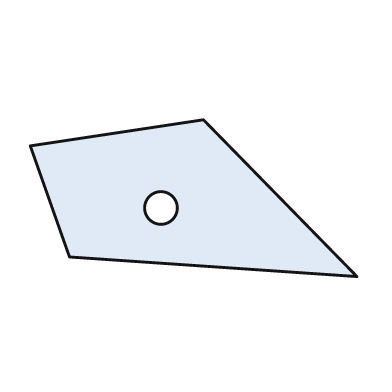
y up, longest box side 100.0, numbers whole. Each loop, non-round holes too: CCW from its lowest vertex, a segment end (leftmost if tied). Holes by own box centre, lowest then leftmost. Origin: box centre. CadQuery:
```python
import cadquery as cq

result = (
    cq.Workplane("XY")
    .moveTo(50.0, -24.0)
    .lineTo(3.0, 24.0)
    .lineTo(-50.0, 16.0)
    .lineTo(-38.0, -18.0)
    .close()
    .moveTo(-10.0, -3.0)
    .circle(5.0)
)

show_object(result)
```